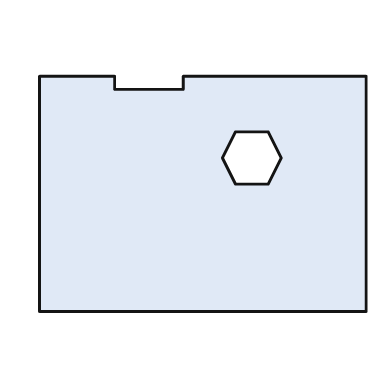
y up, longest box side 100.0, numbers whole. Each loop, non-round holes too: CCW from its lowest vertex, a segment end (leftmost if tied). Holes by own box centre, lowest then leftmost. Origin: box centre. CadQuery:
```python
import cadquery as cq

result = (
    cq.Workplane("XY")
    .moveTo(-50.0, -36.0)
    .lineTo(50.0, -36.0)
    .lineTo(50.0, 36.0)
    .lineTo(-6.0, 36.0)
    .lineTo(-6.0, 32.0)
    .lineTo(-27.0, 32.0)
    .lineTo(-27.0, 36.0)
    .lineTo(-50.0, 36.0)
    .close()
    .moveTo(10.0, 3.0)
    .lineTo(20.0, 3.0)
    .lineTo(24.0, 11.0)
    .lineTo(20.0, 19.0)
    .lineTo(10.0, 19.0)
    .lineTo(6.0, 11.0)
    .close()
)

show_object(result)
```